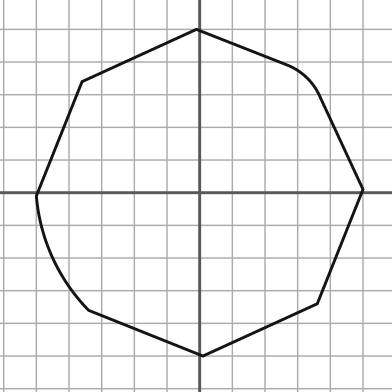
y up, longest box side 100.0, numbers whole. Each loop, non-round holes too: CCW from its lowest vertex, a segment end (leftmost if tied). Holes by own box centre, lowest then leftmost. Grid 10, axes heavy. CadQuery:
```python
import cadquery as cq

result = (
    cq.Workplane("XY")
    .moveTo(1.0, -50.0)
    .lineTo(36.0, -34.0)
    .lineTo(50.0, 1.0)
    .lineTo(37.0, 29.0)
    .threePointArc((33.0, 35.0), (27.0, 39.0))
    .lineTo(-1.0, 50.0)
    .lineTo(-36.0, 34.0)
    .lineTo(-50.0, -1.0)
    .threePointArc((-45.0, -20.0), (-34.0, -36.0))
    .close()
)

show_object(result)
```